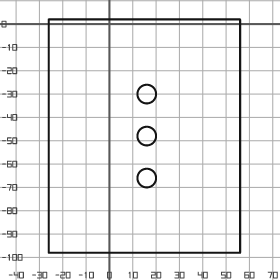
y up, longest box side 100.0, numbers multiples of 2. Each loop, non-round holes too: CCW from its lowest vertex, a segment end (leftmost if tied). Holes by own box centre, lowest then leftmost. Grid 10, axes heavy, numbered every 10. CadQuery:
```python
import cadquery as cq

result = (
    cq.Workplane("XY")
    .moveTo(-26.0, -98.0)
    .lineTo(56.0, -98.0)
    .lineTo(56.0, 2.0)
    .lineTo(-26.0, 2.0)
    .close()
    .moveTo(16.0, -66.0)
    .circle(4.0)
    .moveTo(16.0, -48.0)
    .circle(4.0)
    .moveTo(16.0, -30.0)
    .circle(4.0)
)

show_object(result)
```